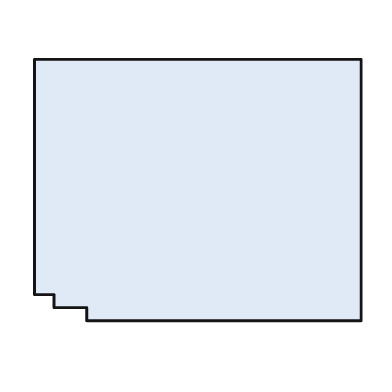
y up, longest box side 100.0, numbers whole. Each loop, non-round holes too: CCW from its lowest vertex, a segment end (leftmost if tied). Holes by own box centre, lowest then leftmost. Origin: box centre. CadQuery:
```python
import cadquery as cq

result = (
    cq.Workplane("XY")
    .moveTo(-34.0, -40.0)
    .lineTo(50.0, -40.0)
    .lineTo(50.0, 40.0)
    .lineTo(-50.0, 40.0)
    .lineTo(-50.0, -32.0)
    .lineTo(-44.0, -32.0)
    .lineTo(-44.0, -36.0)
    .lineTo(-34.0, -36.0)
    .close()
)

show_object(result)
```